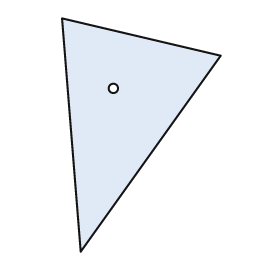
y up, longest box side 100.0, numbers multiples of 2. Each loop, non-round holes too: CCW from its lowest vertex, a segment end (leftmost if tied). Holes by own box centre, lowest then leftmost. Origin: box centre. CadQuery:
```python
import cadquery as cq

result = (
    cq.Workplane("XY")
    .moveTo(-26.0, -50.0)
    .lineTo(34.0, 34.0)
    .lineTo(-34.0, 50.0)
    .close()
    .moveTo(-12.0, 20.0)
    .circle(2.0)
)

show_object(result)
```